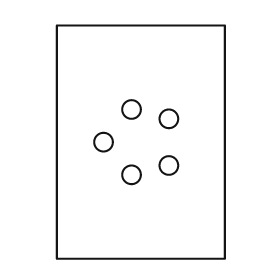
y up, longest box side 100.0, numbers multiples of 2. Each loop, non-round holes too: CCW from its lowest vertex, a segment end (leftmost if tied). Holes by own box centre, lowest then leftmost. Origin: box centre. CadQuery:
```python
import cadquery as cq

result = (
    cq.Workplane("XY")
    .moveTo(-36.0, -50.0)
    .lineTo(36.0, -50.0)
    .lineTo(36.0, 50.0)
    .lineTo(-36.0, 50.0)
    .close()
    .moveTo(-4.0, -14.0)
    .circle(4.0)
    .moveTo(12.0, -10.0)
    .circle(4.0)
    .moveTo(-16.0, 0.0)
    .circle(4.0)
    .moveTo(12.0, 10.0)
    .circle(4.0)
    .moveTo(-4.0, 14.0)
    .circle(4.0)
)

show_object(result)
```